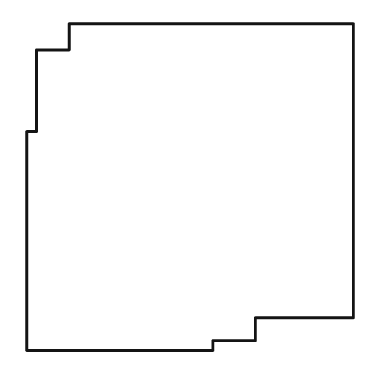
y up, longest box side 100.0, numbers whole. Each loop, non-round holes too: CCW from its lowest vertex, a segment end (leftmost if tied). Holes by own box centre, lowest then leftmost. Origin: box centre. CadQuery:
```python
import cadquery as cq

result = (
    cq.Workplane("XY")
    .moveTo(-50.0, -50.0)
    .lineTo(7.0, -50.0)
    .lineTo(7.0, -47.0)
    .lineTo(20.0, -47.0)
    .lineTo(20.0, -40.0)
    .lineTo(50.0, -40.0)
    .lineTo(50.0, 50.0)
    .lineTo(-37.0, 50.0)
    .lineTo(-37.0, 42.0)
    .lineTo(-47.0, 42.0)
    .lineTo(-47.0, 17.0)
    .lineTo(-50.0, 17.0)
    .close()
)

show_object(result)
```